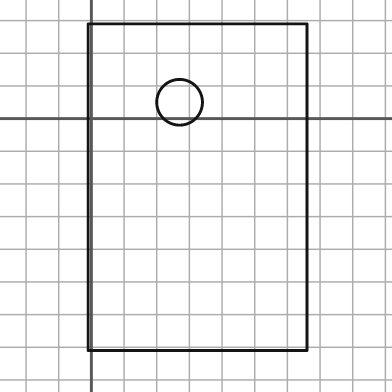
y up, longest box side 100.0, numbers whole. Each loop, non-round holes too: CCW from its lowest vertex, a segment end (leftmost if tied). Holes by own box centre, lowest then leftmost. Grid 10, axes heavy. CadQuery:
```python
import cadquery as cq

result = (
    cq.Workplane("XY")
    .moveTo(-1.0, -71.0)
    .lineTo(66.0, -71.0)
    .lineTo(66.0, 29.0)
    .lineTo(-1.0, 29.0)
    .close()
    .moveTo(27.0, 5.0)
    .circle(7.0)
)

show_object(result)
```